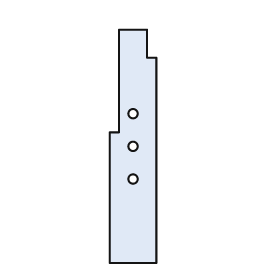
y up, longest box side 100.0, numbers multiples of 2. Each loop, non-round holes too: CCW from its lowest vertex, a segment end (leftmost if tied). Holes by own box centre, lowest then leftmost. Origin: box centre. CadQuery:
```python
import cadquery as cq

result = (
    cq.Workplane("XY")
    .moveTo(-10.0, -50.0)
    .lineTo(10.0, -50.0)
    .lineTo(10.0, 38.0)
    .lineTo(6.0, 38.0)
    .lineTo(6.0, 50.0)
    .lineTo(-6.0, 50.0)
    .lineTo(-6.0, 6.0)
    .lineTo(-10.0, 6.0)
    .close()
    .moveTo(0.0, -14.0)
    .circle(2.0)
    .moveTo(0.0, 0.0)
    .circle(2.0)
    .moveTo(0.0, 14.0)
    .circle(2.0)
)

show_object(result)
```